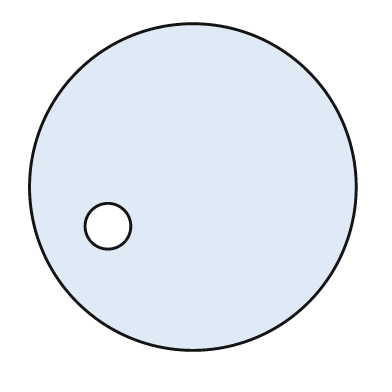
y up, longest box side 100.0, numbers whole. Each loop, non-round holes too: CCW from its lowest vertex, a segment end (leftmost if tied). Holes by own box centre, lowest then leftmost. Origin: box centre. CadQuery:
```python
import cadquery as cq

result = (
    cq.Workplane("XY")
    .moveTo(0.0, 0.0)
    .circle(50.0)
    .moveTo(-26.0, -12.0)
    .circle(7.0)
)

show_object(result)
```